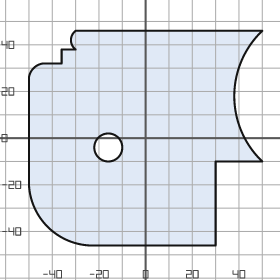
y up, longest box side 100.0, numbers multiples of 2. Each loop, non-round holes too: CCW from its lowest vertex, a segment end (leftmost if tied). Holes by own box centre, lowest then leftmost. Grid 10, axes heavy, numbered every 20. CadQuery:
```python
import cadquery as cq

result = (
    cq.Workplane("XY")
    .moveTo(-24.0, -46.0)
    .lineTo(30.0, -46.0)
    .lineTo(30.0, -10.0)
    .lineTo(50.0, -10.0)
    .threePointArc((38.0, 18.0), (50.0, 46.0))
    .lineTo(-30.0, 46.0)
    .threePointArc((-32.0, 42.0), (-30.0, 38.0))
    .lineTo(-36.0, 38.0)
    .lineTo(-36.0, 32.0)
    .lineTo(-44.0, 32.0)
    .threePointArc((-48.0, 30.0), (-50.0, 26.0))
    .lineTo(-50.0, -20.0)
    .threePointArc((-42.0, -38.0), (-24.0, -46.0))
    .close()
    .moveTo(-16.0, -4.0)
    .circle(6.0)
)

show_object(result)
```